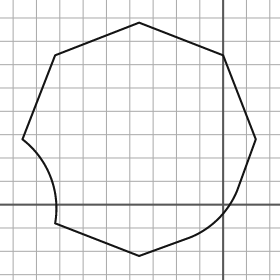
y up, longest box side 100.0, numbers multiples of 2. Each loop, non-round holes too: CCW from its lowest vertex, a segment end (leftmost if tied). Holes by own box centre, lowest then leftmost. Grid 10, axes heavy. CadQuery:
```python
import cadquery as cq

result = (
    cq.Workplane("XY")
    .moveTo(-36.0, -22.0)
    .lineTo(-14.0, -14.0)
    .threePointArc((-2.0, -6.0), (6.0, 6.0))
    .lineTo(14.0, 28.0)
    .lineTo(0.0, 64.0)
    .lineTo(-36.0, 78.0)
    .lineTo(-72.0, 64.0)
    .lineTo(-86.0, 28.0)
    .threePointArc((-74.0, 12.0), (-72.0, -8.0))
    .close()
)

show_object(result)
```